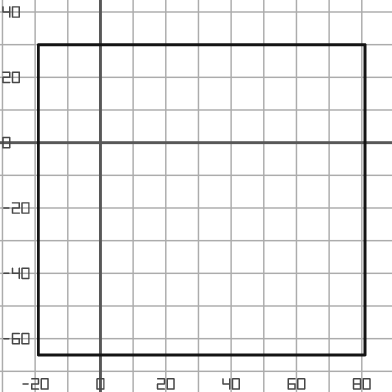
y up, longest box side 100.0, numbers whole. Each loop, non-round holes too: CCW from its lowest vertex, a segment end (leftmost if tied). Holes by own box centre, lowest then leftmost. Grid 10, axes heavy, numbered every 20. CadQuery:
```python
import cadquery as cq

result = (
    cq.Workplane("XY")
    .moveTo(-19.0, -65.0)
    .lineTo(81.0, -65.0)
    .lineTo(81.0, 30.0)
    .lineTo(-19.0, 30.0)
    .close()
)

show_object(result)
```